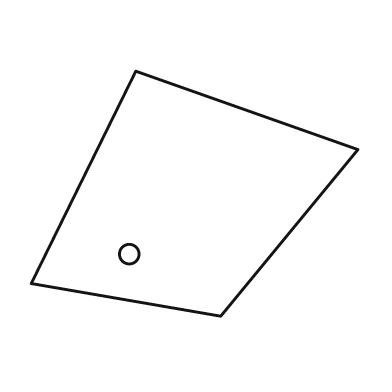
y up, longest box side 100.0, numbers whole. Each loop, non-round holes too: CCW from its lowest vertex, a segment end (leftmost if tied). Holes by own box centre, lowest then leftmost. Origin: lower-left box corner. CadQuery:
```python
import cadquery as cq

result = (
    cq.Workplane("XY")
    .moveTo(58.0, 0.0)
    .lineTo(100.0, 51.0)
    .lineTo(32.0, 75.0)
    .lineTo(0.0, 10.0)
    .close()
    .moveTo(30.0, 19.0)
    .circle(3.0)
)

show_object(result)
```